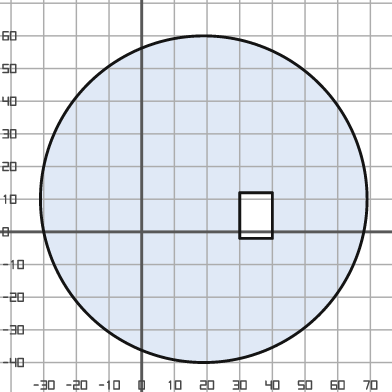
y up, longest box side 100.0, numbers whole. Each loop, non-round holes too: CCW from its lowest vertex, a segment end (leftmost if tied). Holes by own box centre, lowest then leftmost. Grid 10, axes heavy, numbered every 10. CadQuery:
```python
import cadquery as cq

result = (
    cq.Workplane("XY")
    .moveTo(19.0, 10.0)
    .circle(50.0)
    .moveTo(30.0, -2.0)
    .lineTo(40.0, -2.0)
    .lineTo(40.0, 12.0)
    .lineTo(30.0, 12.0)
    .close()
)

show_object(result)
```